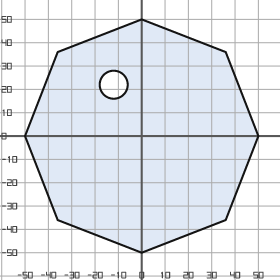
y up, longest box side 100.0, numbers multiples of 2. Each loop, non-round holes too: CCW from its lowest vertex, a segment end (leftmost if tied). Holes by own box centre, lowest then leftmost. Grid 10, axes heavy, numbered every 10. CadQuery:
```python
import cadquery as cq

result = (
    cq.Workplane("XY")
    .moveTo(0.0, -50.0)
    .lineTo(36.0, -36.0)
    .lineTo(50.0, 0.0)
    .lineTo(36.0, 36.0)
    .lineTo(0.0, 50.0)
    .lineTo(-36.0, 36.0)
    .lineTo(-50.0, 0.0)
    .lineTo(-36.0, -36.0)
    .close()
    .moveTo(-12.0, 22.0)
    .circle(6.0)
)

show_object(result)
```